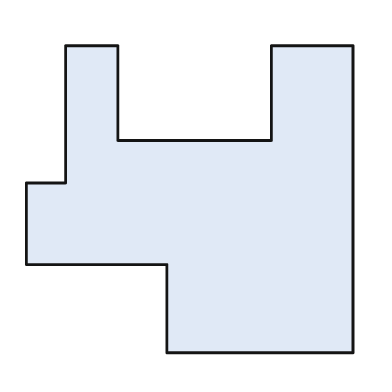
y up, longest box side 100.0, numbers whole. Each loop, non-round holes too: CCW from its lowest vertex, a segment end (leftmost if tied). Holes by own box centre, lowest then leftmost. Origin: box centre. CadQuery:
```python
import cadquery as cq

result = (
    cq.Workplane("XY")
    .moveTo(-7.0, -47.0)
    .lineTo(50.0, -47.0)
    .lineTo(50.0, 47.0)
    .lineTo(25.0, 47.0)
    .lineTo(25.0, 18.0)
    .lineTo(-22.0, 18.0)
    .lineTo(-22.0, 47.0)
    .lineTo(-38.0, 47.0)
    .lineTo(-38.0, 5.0)
    .lineTo(-50.0, 5.0)
    .lineTo(-50.0, -20.0)
    .lineTo(-7.0, -20.0)
    .close()
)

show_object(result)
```